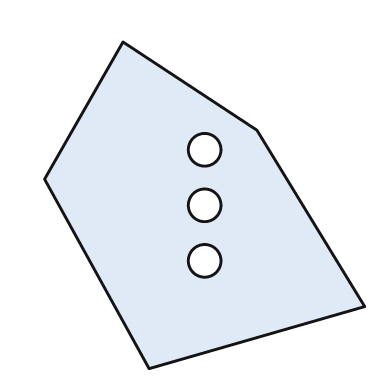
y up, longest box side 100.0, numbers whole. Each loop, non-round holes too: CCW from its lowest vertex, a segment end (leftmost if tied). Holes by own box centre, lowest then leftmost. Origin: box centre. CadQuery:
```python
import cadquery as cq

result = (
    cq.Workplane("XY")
    .moveTo(-17.0, -50.0)
    .lineTo(49.0, -31.0)
    .lineTo(16.0, 23.0)
    .lineTo(-25.0, 50.0)
    .lineTo(-49.0, 8.0)
    .close()
    .moveTo(0.0, -17.0)
    .circle(5.0)
    .moveTo(0.0, 0.0)
    .circle(5.0)
    .moveTo(0.0, 17.0)
    .circle(5.0)
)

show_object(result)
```